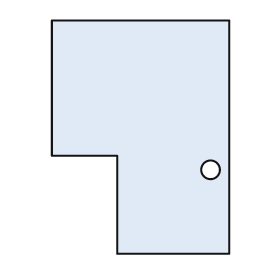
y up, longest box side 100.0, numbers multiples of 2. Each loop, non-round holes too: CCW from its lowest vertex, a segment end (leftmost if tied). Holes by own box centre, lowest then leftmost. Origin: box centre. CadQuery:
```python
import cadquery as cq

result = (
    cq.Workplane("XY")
    .moveTo(-10.0, -50.0)
    .lineTo(38.0, -50.0)
    .lineTo(38.0, 50.0)
    .lineTo(-38.0, 50.0)
    .lineTo(-38.0, -8.0)
    .lineTo(-10.0, -8.0)
    .close()
    .moveTo(30.0, -14.0)
    .circle(4.0)
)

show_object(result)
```